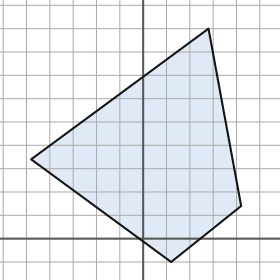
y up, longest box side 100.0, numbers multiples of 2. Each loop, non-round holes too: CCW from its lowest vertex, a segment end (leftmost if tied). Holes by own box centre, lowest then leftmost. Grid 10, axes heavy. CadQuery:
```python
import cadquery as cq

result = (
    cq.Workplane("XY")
    .moveTo(12.0, -10.0)
    .lineTo(42.0, 14.0)
    .lineTo(28.0, 90.0)
    .lineTo(-48.0, 34.0)
    .close()
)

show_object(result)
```